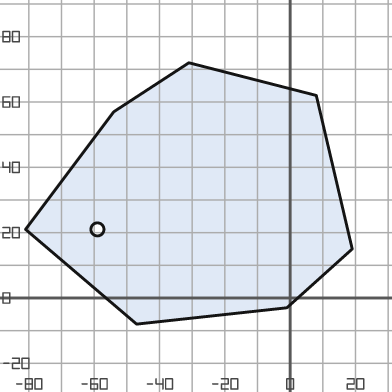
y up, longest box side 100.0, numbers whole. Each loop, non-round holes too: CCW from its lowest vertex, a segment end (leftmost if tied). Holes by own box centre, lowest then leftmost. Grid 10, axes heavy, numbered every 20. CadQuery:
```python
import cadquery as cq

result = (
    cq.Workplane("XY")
    .moveTo(-47.0, -8.0)
    .lineTo(-1.0, -3.0)
    .lineTo(19.0, 15.0)
    .lineTo(8.0, 62.0)
    .lineTo(-31.0, 72.0)
    .lineTo(-54.0, 57.0)
    .lineTo(-81.0, 21.0)
    .close()
    .moveTo(-59.0, 21.0)
    .circle(2.0)
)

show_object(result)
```